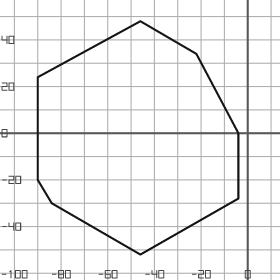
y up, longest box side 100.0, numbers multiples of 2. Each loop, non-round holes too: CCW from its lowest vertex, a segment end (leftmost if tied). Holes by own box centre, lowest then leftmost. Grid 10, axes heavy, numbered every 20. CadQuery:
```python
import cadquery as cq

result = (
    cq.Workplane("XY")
    .moveTo(-46.0, -52.0)
    .lineTo(-4.0, -28.0)
    .lineTo(-4.0, 0.0)
    .lineTo(-22.0, 34.0)
    .lineTo(-46.0, 48.0)
    .lineTo(-90.0, 24.0)
    .lineTo(-90.0, -20.0)
    .lineTo(-84.0, -30.0)
    .close()
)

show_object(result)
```